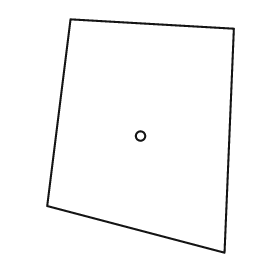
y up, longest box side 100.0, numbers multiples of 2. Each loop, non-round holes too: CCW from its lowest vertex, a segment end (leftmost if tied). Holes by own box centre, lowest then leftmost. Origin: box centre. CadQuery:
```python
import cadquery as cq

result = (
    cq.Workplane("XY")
    .moveTo(36.0, -50.0)
    .lineTo(40.0, 46.0)
    .lineTo(-30.0, 50.0)
    .lineTo(-40.0, -30.0)
    .close()
    .moveTo(0.0, 0.0)
    .circle(2.0)
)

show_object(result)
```